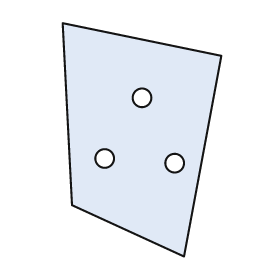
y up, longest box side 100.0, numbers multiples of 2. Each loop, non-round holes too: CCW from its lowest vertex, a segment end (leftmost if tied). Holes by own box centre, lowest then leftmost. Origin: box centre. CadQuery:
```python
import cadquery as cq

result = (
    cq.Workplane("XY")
    .moveTo(18.0, -50.0)
    .lineTo(34.0, 36.0)
    .lineTo(-34.0, 50.0)
    .lineTo(-30.0, -28.0)
    .close()
    .moveTo(14.0, -10.0)
    .circle(4.0)
    .moveTo(-16.0, -8.0)
    .circle(4.0)
    .moveTo(0.0, 18.0)
    .circle(4.0)
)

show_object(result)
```